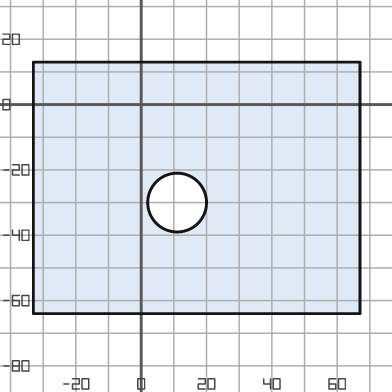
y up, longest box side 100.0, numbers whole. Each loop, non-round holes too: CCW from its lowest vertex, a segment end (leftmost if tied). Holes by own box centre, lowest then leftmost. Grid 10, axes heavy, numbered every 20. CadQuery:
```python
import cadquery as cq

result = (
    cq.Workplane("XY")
    .moveTo(-33.0, -64.0)
    .lineTo(67.0, -64.0)
    .lineTo(67.0, 13.0)
    .lineTo(-33.0, 13.0)
    .close()
    .moveTo(11.0, -30.0)
    .circle(9.0)
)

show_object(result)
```